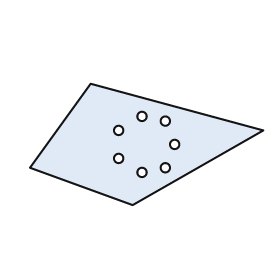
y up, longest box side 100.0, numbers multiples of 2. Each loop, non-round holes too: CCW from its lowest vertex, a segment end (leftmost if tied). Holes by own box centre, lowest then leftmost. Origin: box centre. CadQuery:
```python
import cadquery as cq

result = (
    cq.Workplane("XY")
    .moveTo(-6.0, -26.0)
    .lineTo(50.0, 6.0)
    .lineTo(-24.0, 26.0)
    .lineTo(-50.0, -10.0)
    .close()
    .moveTo(-2.0, -12.0)
    .circle(2.0)
    .moveTo(8.0, -10.0)
    .circle(2.0)
    .moveTo(-12.0, -6.0)
    .circle(2.0)
    .moveTo(12.0, 0.0)
    .circle(2.0)
    .moveTo(-12.0, 6.0)
    .circle(2.0)
    .moveTo(8.0, 10.0)
    .circle(2.0)
    .moveTo(-2.0, 12.0)
    .circle(2.0)
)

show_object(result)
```